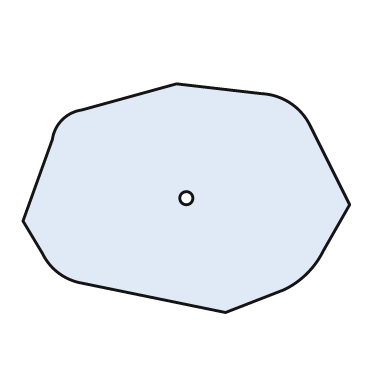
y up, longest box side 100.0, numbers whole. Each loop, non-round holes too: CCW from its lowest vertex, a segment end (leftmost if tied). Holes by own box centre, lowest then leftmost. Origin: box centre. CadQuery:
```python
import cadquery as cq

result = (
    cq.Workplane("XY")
    .moveTo(12.0, -35.0)
    .lineTo(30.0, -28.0)
    .threePointArc((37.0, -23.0), (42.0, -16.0))
    .lineTo(50.0, -2.0)
    .lineTo(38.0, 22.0)
    .threePointArc((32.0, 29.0), (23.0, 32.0))
    .lineTo(-3.0, 35.0)
    .lineTo(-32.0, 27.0)
    .threePointArc((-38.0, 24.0), (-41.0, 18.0))
    .lineTo(-50.0, -7.0)
    .lineTo(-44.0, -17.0)
    .threePointArc((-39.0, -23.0), (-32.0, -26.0))
    .close()
    .moveTo(0.0, 0.0)
    .circle(2.0)
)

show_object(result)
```